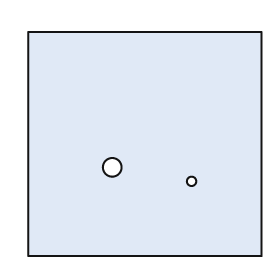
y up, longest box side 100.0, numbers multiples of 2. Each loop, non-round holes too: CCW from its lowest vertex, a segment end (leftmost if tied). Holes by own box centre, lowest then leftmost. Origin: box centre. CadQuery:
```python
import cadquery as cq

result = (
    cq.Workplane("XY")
    .moveTo(-50.0, -48.0)
    .lineTo(50.0, -48.0)
    .lineTo(50.0, 48.0)
    .lineTo(-50.0, 48.0)
    .close()
    .moveTo(20.0, -16.0)
    .circle(2.0)
    .moveTo(-14.0, -10.0)
    .circle(4.0)
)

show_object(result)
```